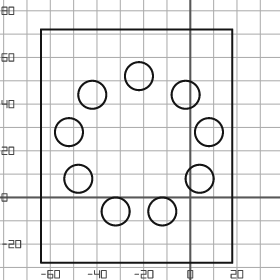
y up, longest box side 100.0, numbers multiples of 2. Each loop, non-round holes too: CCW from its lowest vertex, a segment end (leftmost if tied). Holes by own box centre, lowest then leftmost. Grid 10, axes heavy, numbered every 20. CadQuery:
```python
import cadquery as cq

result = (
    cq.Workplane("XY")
    .moveTo(-64.0, -28.0)
    .lineTo(18.0, -28.0)
    .lineTo(18.0, 72.0)
    .lineTo(-64.0, 72.0)
    .close()
    .moveTo(-32.0, -6.0)
    .circle(6.0)
    .moveTo(-12.0, -6.0)
    .circle(6.0)
    .moveTo(-48.0, 8.0)
    .circle(6.0)
    .moveTo(4.0, 8.0)
    .circle(6.0)
    .moveTo(-52.0, 28.0)
    .circle(6.0)
    .moveTo(8.0, 28.0)
    .circle(6.0)
    .moveTo(-42.0, 44.0)
    .circle(6.0)
    .moveTo(-2.0, 44.0)
    .circle(6.0)
    .moveTo(-22.0, 52.0)
    .circle(6.0)
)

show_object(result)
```